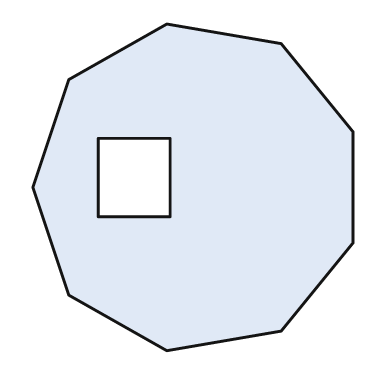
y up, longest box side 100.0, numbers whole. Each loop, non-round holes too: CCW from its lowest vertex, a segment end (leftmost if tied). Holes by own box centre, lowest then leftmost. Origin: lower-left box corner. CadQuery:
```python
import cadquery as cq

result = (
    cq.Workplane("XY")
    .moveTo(41.0, 0.0)
    .lineTo(76.0, 6.0)
    .lineTo(98.0, 33.0)
    .lineTo(98.0, 67.0)
    .lineTo(76.0, 94.0)
    .lineTo(41.0, 100.0)
    .lineTo(11.0, 83.0)
    .lineTo(0.0, 50.0)
    .lineTo(11.0, 17.0)
    .close()
    .moveTo(20.0, 41.0)
    .lineTo(42.0, 41.0)
    .lineTo(42.0, 65.0)
    .lineTo(20.0, 65.0)
    .close()
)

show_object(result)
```